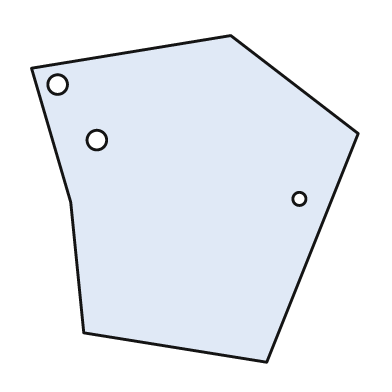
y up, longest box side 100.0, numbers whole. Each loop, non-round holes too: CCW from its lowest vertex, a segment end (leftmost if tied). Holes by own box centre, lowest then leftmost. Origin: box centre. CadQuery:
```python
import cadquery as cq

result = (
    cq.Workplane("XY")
    .moveTo(22.0, -50.0)
    .lineTo(50.0, 20.0)
    .lineTo(11.0, 50.0)
    .lineTo(-50.0, 40.0)
    .lineTo(-38.0, -1.0)
    .lineTo(-34.0, -41.0)
    .close()
    .moveTo(32.0, 0.0)
    .circle(2.0)
    .moveTo(-30.0, 18.0)
    .circle(3.0)
    .moveTo(-42.0, 35.0)
    .circle(3.0)
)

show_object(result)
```